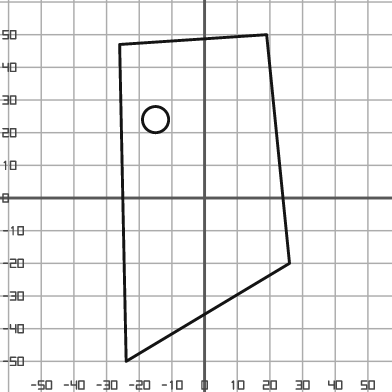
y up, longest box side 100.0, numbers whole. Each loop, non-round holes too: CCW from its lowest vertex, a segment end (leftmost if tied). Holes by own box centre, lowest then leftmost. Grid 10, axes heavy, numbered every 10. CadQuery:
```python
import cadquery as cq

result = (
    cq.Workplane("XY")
    .moveTo(-24.0, -50.0)
    .lineTo(26.0, -20.0)
    .lineTo(19.0, 50.0)
    .lineTo(-26.0, 47.0)
    .close()
    .moveTo(-15.0, 24.0)
    .circle(4.0)
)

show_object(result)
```